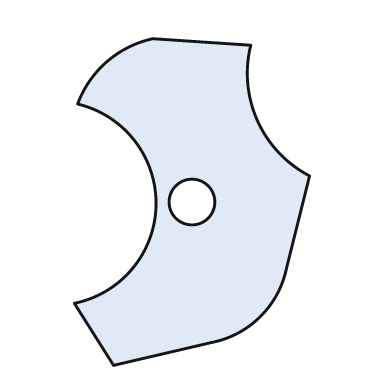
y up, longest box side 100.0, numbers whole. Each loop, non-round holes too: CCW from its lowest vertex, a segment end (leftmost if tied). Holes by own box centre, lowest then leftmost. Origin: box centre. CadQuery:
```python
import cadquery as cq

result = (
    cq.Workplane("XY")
    .moveTo(-24.0, -50.0)
    .lineTo(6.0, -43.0)
    .threePointArc((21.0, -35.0), (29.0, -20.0))
    .lineTo(36.0, 8.0)
    .threePointArc((20.0, 25.0), (18.0, 48.0))
    .lineTo(-12.0, 50.0)
    .threePointArc((-26.0, 43.0), (-35.0, 30.0))
    .threePointArc((-11.0, -1.0), (-36.0, -31.0))
    .close()
    .moveTo(0.0, 0.0)
    .circle(7.0)
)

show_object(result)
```